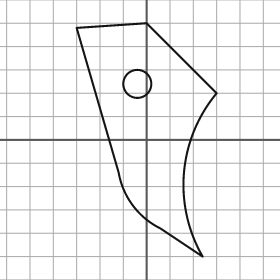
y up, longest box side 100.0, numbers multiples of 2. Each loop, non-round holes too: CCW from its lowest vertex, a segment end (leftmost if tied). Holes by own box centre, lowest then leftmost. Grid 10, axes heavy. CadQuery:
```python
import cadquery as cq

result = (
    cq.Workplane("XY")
    .moveTo(24.0, -50.0)
    .threePointArc((16.0, -14.0), (30.0, 20.0))
    .lineTo(0.0, 50.0)
    .lineTo(-30.0, 48.0)
    .lineTo(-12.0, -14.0)
    .threePointArc((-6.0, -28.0), (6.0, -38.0))
    .close()
    .moveTo(-4.0, 24.0)
    .circle(6.0)
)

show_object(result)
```